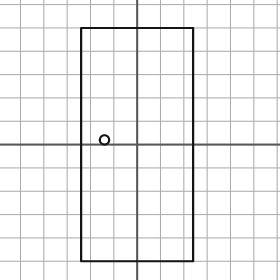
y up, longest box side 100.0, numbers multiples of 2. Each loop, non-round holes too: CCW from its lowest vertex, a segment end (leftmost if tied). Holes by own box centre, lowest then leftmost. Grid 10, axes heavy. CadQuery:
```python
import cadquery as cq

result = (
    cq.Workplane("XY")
    .moveTo(-24.0, -50.0)
    .lineTo(24.0, -50.0)
    .lineTo(24.0, 50.0)
    .lineTo(-24.0, 50.0)
    .close()
    .moveTo(-14.0, 2.0)
    .circle(2.0)
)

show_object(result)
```